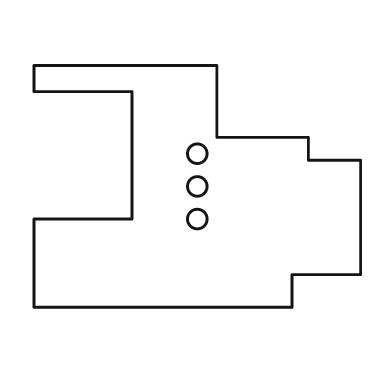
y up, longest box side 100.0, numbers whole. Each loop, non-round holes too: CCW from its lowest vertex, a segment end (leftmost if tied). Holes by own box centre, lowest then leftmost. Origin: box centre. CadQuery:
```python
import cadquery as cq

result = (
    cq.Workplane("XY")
    .moveTo(-50.0, -37.0)
    .lineTo(29.0, -37.0)
    .lineTo(29.0, -27.0)
    .lineTo(50.0, -27.0)
    .lineTo(50.0, 8.0)
    .lineTo(34.0, 8.0)
    .lineTo(34.0, 15.0)
    .lineTo(6.0, 15.0)
    .lineTo(6.0, 37.0)
    .lineTo(-50.0, 37.0)
    .lineTo(-50.0, 29.0)
    .lineTo(-20.0, 29.0)
    .lineTo(-20.0, -10.0)
    .lineTo(-50.0, -10.0)
    .close()
    .moveTo(0.0, -10.0)
    .circle(3.0)
    .moveTo(0.0, 0.0)
    .circle(3.0)
    .moveTo(0.0, 10.0)
    .circle(3.0)
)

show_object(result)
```